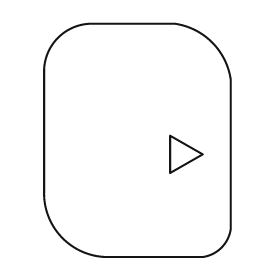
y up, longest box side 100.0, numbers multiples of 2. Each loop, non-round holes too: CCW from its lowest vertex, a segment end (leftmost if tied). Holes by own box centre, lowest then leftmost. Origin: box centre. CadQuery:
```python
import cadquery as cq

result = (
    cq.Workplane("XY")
    .moveTo(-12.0, -50.0)
    .lineTo(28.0, -50.0)
    .threePointArc((36.0, -46.0), (40.0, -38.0))
    .lineTo(40.0, 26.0)
    .threePointArc((32.0, 42.0), (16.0, 50.0))
    .lineTo(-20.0, 50.0)
    .threePointArc((-34.0, 44.0), (-40.0, 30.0))
    .lineTo(-40.0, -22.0)
    .threePointArc((-32.0, -42.0), (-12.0, -50.0))
    .close()
    .moveTo(14.0, -14.0)
    .lineTo(28.0, -6.0)
    .lineTo(14.0, 2.0)
    .close()
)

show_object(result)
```